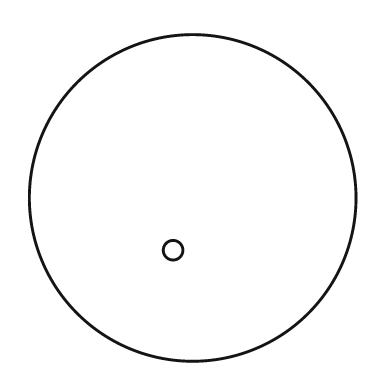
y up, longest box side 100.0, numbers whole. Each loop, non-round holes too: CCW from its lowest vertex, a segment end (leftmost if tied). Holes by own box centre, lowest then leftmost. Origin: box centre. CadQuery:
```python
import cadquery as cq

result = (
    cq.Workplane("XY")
    .moveTo(0.0, 0.0)
    .circle(50.0)
    .moveTo(-6.0, -16.0)
    .circle(3.0)
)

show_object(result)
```